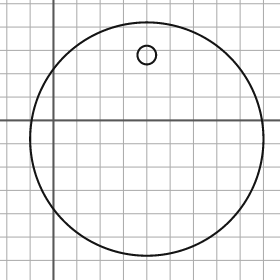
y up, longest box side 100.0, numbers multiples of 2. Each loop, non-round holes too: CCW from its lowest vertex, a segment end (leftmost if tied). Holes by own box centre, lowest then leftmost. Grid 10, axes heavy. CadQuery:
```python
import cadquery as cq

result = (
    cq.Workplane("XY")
    .moveTo(40.0, -8.0)
    .circle(50.0)
    .moveTo(40.0, 28.0)
    .circle(4.0)
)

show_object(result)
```